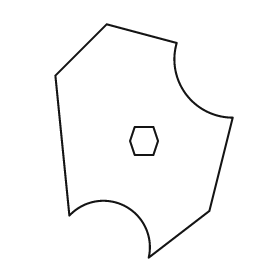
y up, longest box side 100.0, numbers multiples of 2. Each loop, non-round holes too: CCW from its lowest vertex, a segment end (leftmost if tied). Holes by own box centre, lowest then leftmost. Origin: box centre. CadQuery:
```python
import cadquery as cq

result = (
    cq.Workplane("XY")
    .moveTo(2.0, -50.0)
    .lineTo(28.0, -30.0)
    .lineTo(38.0, 10.0)
    .threePointArc((18.0, 20.0), (14.0, 42.0))
    .lineTo(-16.0, 50.0)
    .lineTo(-38.0, 28.0)
    .lineTo(-32.0, -32.0)
    .threePointArc((-8.0, -28.0), (2.0, -50.0))
    .close()
    .moveTo(-4.0, -6.0)
    .lineTo(4.0, -6.0)
    .lineTo(6.0, 0.0)
    .lineTo(4.0, 6.0)
    .lineTo(-4.0, 6.0)
    .lineTo(-6.0, 0.0)
    .close()
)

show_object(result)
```